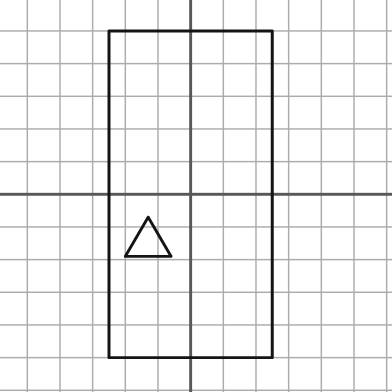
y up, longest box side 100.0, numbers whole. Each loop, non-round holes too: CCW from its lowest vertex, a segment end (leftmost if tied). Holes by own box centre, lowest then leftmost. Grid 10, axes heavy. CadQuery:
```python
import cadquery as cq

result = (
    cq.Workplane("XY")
    .moveTo(-25.0, -50.0)
    .lineTo(25.0, -50.0)
    .lineTo(25.0, 50.0)
    .lineTo(-25.0, 50.0)
    .close()
    .moveTo(-20.0, -19.0)
    .lineTo(-6.0, -19.0)
    .lineTo(-13.0, -7.0)
    .close()
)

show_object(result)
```